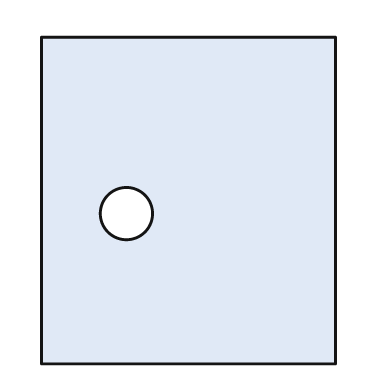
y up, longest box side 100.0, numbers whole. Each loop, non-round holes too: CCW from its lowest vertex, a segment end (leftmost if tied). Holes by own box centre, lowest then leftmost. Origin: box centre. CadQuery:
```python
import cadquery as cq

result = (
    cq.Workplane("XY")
    .moveTo(-45.0, -50.0)
    .lineTo(45.0, -50.0)
    .lineTo(45.0, 50.0)
    .lineTo(-45.0, 50.0)
    .close()
    .moveTo(-19.0, -4.0)
    .circle(8.0)
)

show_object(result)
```